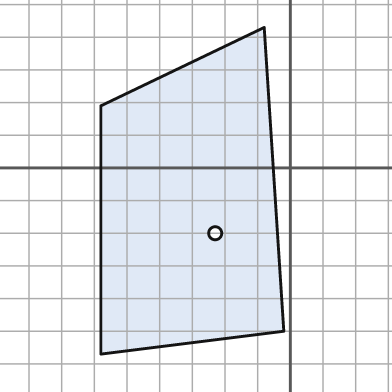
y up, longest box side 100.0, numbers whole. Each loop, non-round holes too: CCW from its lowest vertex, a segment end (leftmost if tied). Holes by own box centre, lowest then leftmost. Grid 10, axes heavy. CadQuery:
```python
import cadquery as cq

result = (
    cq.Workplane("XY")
    .moveTo(-58.0, -57.0)
    .lineTo(-2.0, -50.0)
    .lineTo(-8.0, 43.0)
    .lineTo(-58.0, 19.0)
    .close()
    .moveTo(-23.0, -20.0)
    .circle(2.0)
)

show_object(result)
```